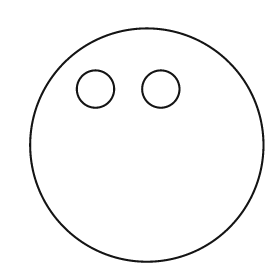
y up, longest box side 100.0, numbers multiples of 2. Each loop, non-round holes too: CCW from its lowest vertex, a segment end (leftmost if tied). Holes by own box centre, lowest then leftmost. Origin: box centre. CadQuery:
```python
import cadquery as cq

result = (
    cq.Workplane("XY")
    .moveTo(0.0, 0.0)
    .circle(50.0)
    .moveTo(-22.0, 24.0)
    .circle(8.0)
    .moveTo(6.0, 24.0)
    .circle(8.0)
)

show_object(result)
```